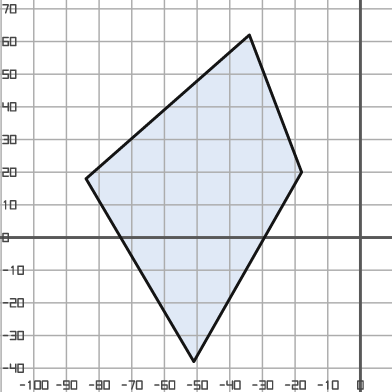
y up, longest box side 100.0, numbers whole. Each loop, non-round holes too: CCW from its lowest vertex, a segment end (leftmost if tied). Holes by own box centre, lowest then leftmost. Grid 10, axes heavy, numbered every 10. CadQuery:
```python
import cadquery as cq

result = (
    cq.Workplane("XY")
    .moveTo(-51.0, -38.0)
    .lineTo(-18.0, 20.0)
    .lineTo(-34.0, 62.0)
    .lineTo(-84.0, 18.0)
    .close()
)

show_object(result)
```